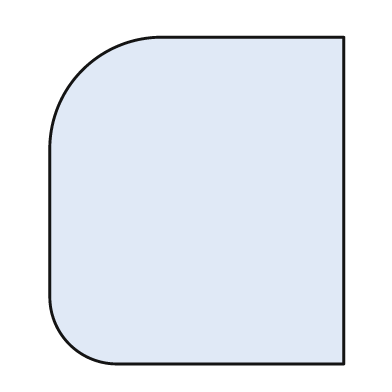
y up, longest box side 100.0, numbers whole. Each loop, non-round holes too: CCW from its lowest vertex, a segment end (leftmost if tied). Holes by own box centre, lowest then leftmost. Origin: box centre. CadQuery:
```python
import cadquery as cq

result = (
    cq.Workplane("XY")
    .moveTo(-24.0, -50.0)
    .lineTo(45.0, -50.0)
    .lineTo(45.0, 50.0)
    .lineTo(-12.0, 50.0)
    .threePointArc((-35.0, 40.0), (-45.0, 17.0))
    .lineTo(-45.0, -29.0)
    .threePointArc((-39.0, -44.0), (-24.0, -50.0))
    .close()
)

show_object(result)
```